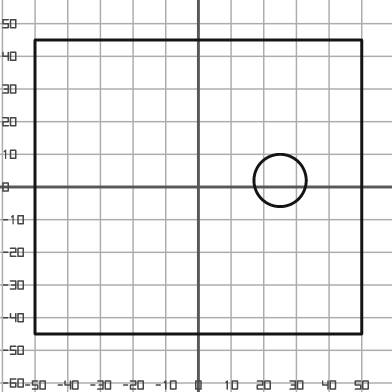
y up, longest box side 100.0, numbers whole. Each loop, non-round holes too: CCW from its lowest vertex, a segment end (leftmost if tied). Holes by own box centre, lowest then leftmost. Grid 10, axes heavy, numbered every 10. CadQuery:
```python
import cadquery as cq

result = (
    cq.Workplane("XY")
    .moveTo(-50.0, -45.0)
    .lineTo(50.0, -45.0)
    .lineTo(50.0, 45.0)
    .lineTo(-50.0, 45.0)
    .close()
    .moveTo(25.0, 2.0)
    .circle(8.0)
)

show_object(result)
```